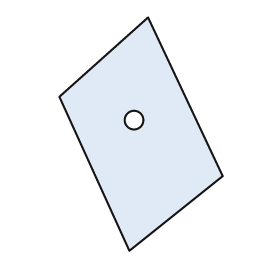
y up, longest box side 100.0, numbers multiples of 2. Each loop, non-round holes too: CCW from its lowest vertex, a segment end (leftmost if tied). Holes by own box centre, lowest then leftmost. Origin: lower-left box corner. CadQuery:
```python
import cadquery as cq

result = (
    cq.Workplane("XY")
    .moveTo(30.0, 0.0)
    .lineTo(70.0, 32.0)
    .lineTo(38.0, 100.0)
    .lineTo(0.0, 66.0)
    .close()
    .moveTo(32.0, 56.0)
    .circle(4.0)
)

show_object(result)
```